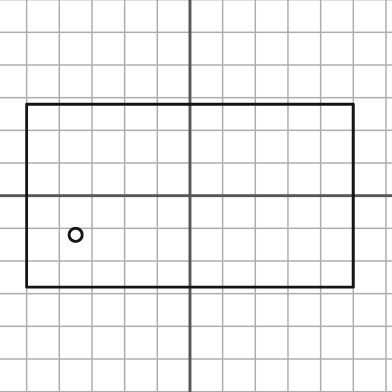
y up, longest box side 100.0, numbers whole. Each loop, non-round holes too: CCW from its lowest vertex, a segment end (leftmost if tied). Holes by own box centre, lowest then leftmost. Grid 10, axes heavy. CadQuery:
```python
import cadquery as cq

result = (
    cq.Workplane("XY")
    .moveTo(-50.0, -28.0)
    .lineTo(50.0, -28.0)
    .lineTo(50.0, 28.0)
    .lineTo(-50.0, 28.0)
    .close()
    .moveTo(-35.0, -12.0)
    .circle(2.0)
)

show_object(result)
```